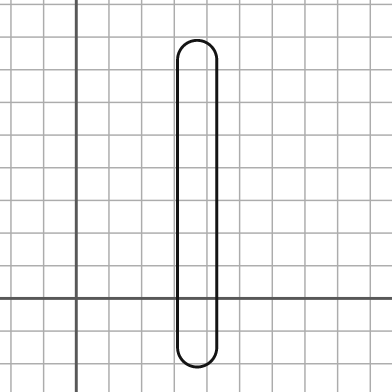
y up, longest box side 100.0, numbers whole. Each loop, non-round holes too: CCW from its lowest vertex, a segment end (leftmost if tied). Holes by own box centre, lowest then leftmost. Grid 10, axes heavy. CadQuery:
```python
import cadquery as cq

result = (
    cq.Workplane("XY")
    .moveTo(31.0, -15.0)
    .threePointArc((37.0, -21.0), (43.0, -15.0))
    .lineTo(43.0, 73.0)
    .threePointArc((37.0, 79.0), (31.0, 73.0))
    .close()
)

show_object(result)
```